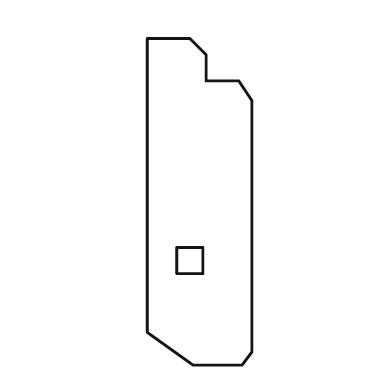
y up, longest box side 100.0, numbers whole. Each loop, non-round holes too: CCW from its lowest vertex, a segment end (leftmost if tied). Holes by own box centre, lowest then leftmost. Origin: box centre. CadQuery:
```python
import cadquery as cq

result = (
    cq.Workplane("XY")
    .moveTo(-2.0, -50.0)
    .lineTo(13.0, -50.0)
    .lineTo(16.0, -46.0)
    .lineTo(16.0, 31.0)
    .lineTo(12.0, 37.0)
    .lineTo(2.0, 37.0)
    .lineTo(2.0, 45.0)
    .lineTo(-3.0, 50.0)
    .lineTo(-16.0, 50.0)
    .lineTo(-16.0, -40.0)
    .close()
    .moveTo(-7.0, -22.0)
    .lineTo(1.0, -22.0)
    .lineTo(1.0, -14.0)
    .lineTo(-7.0, -14.0)
    .close()
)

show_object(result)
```